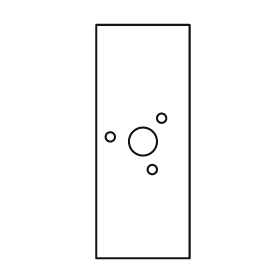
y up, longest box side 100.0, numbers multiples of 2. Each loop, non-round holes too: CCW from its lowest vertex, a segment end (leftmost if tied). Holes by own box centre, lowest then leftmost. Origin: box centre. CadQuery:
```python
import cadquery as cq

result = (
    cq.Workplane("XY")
    .moveTo(-20.0, -50.0)
    .lineTo(20.0, -50.0)
    .lineTo(20.0, 50.0)
    .lineTo(-20.0, 50.0)
    .close()
    .moveTo(4.0, -12.0)
    .circle(2.0)
    .moveTo(0.0, 0.0)
    .circle(6.0)
    .moveTo(-14.0, 2.0)
    .circle(2.0)
    .moveTo(8.0, 10.0)
    .circle(2.0)
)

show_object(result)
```